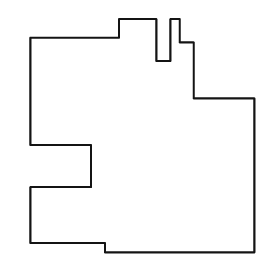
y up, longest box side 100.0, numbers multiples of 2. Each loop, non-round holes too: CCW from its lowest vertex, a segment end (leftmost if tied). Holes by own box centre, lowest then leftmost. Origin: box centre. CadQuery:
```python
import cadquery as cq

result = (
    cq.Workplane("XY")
    .moveTo(-16.0, -50.0)
    .lineTo(48.0, -50.0)
    .lineTo(48.0, 16.0)
    .lineTo(22.0, 16.0)
    .lineTo(22.0, 40.0)
    .lineTo(16.0, 40.0)
    .lineTo(16.0, 50.0)
    .lineTo(12.0, 50.0)
    .lineTo(12.0, 32.0)
    .lineTo(6.0, 32.0)
    .lineTo(6.0, 50.0)
    .lineTo(-10.0, 50.0)
    .lineTo(-10.0, 42.0)
    .lineTo(-48.0, 42.0)
    .lineTo(-48.0, -4.0)
    .lineTo(-22.0, -4.0)
    .lineTo(-22.0, -22.0)
    .lineTo(-48.0, -22.0)
    .lineTo(-48.0, -46.0)
    .lineTo(-16.0, -46.0)
    .close()
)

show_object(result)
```